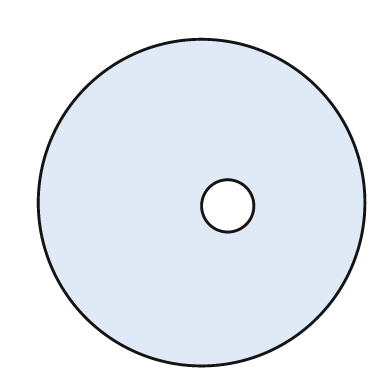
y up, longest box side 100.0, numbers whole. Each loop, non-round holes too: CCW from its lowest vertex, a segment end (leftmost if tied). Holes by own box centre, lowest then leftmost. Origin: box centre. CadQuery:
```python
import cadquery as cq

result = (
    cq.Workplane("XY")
    .moveTo(0.0, 0.0)
    .circle(50.0)
    .moveTo(8.0, -1.0)
    .circle(8.0)
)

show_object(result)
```